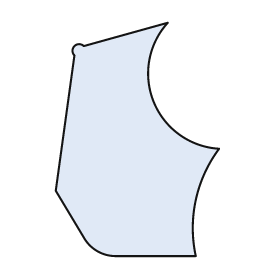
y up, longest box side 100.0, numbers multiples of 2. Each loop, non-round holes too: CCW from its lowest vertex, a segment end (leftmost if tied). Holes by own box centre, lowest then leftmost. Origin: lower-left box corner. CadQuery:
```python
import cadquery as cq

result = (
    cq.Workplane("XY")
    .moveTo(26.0, 0.0)
    .lineTo(60.0, 0.0)
    .threePointArc((60.0, 24.0), (70.0, 46.0))
    .threePointArc((42.0, 66.0), (48.0, 100.0))
    .lineTo(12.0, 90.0)
    .threePointArc((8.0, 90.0), (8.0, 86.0))
    .lineTo(0.0, 28.0)
    .lineTo(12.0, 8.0)
    .threePointArc((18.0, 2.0), (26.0, 0.0))
    .close()
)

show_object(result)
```